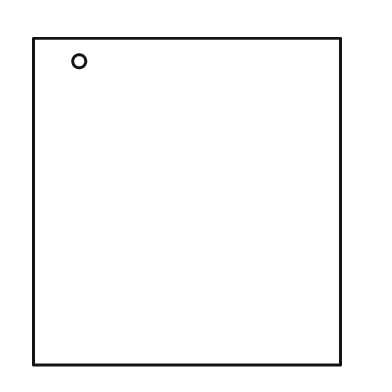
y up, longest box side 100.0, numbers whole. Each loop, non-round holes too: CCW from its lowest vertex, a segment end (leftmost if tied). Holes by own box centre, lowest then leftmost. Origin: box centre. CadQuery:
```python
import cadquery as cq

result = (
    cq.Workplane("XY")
    .moveTo(-47.0, -50.0)
    .lineTo(47.0, -50.0)
    .lineTo(47.0, 50.0)
    .lineTo(-47.0, 50.0)
    .close()
    .moveTo(-33.0, 43.0)
    .circle(2.0)
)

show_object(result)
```